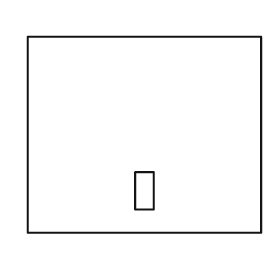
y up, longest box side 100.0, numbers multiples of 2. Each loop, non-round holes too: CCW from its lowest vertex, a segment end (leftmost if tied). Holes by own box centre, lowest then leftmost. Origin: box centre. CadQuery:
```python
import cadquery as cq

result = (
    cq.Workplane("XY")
    .moveTo(-50.0, -42.0)
    .lineTo(50.0, -42.0)
    .lineTo(50.0, 42.0)
    .lineTo(-50.0, 42.0)
    .close()
    .moveTo(-4.0, -32.0)
    .lineTo(4.0, -32.0)
    .lineTo(4.0, -16.0)
    .lineTo(-4.0, -16.0)
    .close()
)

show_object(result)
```